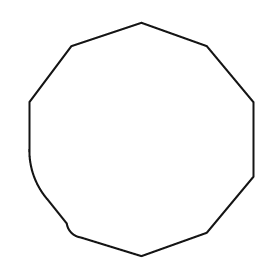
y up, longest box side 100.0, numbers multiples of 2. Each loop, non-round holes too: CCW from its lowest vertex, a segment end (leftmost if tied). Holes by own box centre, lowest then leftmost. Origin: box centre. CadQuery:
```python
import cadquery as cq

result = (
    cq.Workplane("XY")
    .moveTo(0.0, -50.0)
    .lineTo(28.0, -40.0)
    .lineTo(48.0, -16.0)
    .lineTo(48.0, 16.0)
    .lineTo(28.0, 40.0)
    .lineTo(0.0, 50.0)
    .lineTo(-30.0, 40.0)
    .lineTo(-48.0, 16.0)
    .lineTo(-48.0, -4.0)
    .threePointArc((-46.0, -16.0), (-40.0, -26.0))
    .lineTo(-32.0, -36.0)
    .threePointArc((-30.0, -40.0), (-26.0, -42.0))
    .close()
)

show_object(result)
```